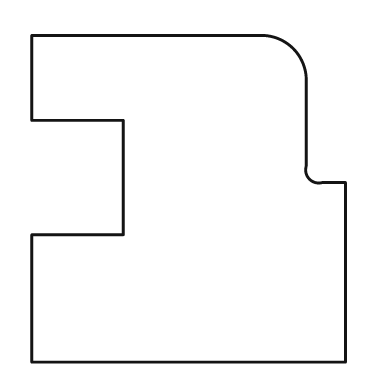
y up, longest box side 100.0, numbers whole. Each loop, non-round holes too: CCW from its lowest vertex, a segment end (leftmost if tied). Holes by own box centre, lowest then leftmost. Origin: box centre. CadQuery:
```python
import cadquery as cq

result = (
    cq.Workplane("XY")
    .moveTo(-48.0, -50.0)
    .lineTo(48.0, -50.0)
    .lineTo(48.0, 5.0)
    .lineTo(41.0, 5.0)
    .threePointArc((37.0, 6.0), (36.0, 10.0))
    .lineTo(36.0, 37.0)
    .threePointArc((32.0, 46.0), (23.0, 50.0))
    .lineTo(-48.0, 50.0)
    .lineTo(-48.0, 24.0)
    .lineTo(-20.0, 24.0)
    .lineTo(-20.0, -11.0)
    .lineTo(-48.0, -11.0)
    .close()
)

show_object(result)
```